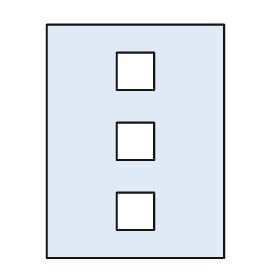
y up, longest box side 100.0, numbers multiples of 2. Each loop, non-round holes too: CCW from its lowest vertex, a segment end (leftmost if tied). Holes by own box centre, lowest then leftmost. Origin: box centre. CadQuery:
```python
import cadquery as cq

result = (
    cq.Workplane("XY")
    .moveTo(-38.0, -50.0)
    .lineTo(38.0, -50.0)
    .lineTo(38.0, 50.0)
    .lineTo(-38.0, 50.0)
    .close()
    .moveTo(-8.0, -38.0)
    .lineTo(8.0, -38.0)
    .lineTo(8.0, -22.0)
    .lineTo(-8.0, -22.0)
    .close()
    .moveTo(-8.0, -8.0)
    .lineTo(8.0, -8.0)
    .lineTo(8.0, 8.0)
    .lineTo(-8.0, 8.0)
    .close()
    .moveTo(-8.0, 22.0)
    .lineTo(8.0, 22.0)
    .lineTo(8.0, 38.0)
    .lineTo(-8.0, 38.0)
    .close()
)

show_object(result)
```